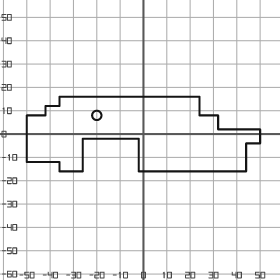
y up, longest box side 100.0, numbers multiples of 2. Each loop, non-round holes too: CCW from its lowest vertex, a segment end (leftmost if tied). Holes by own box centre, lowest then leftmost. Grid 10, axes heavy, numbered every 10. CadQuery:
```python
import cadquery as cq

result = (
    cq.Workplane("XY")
    .moveTo(-36.0, -16.0)
    .lineTo(-26.0, -16.0)
    .lineTo(-26.0, -2.0)
    .lineTo(-2.0, -2.0)
    .lineTo(-2.0, -16.0)
    .lineTo(44.0, -16.0)
    .lineTo(44.0, -4.0)
    .lineTo(50.0, -4.0)
    .lineTo(50.0, 2.0)
    .lineTo(32.0, 2.0)
    .lineTo(32.0, 8.0)
    .lineTo(24.0, 8.0)
    .lineTo(24.0, 16.0)
    .lineTo(-36.0, 16.0)
    .lineTo(-36.0, 12.0)
    .lineTo(-42.0, 12.0)
    .lineTo(-42.0, 8.0)
    .lineTo(-50.0, 8.0)
    .lineTo(-50.0, -12.0)
    .lineTo(-36.0, -12.0)
    .close()
    .moveTo(-20.0, 8.0)
    .circle(2.0)
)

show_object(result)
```